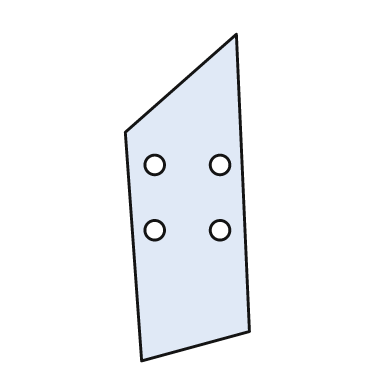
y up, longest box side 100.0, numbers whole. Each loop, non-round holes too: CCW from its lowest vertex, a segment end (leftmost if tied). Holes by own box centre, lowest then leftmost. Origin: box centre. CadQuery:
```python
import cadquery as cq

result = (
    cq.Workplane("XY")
    .moveTo(-14.0, -50.0)
    .lineTo(19.0, -41.0)
    .lineTo(15.0, 50.0)
    .lineTo(-19.0, 20.0)
    .close()
    .moveTo(-10.0, -10.0)
    .circle(3.0)
    .moveTo(10.0, -10.0)
    .circle(3.0)
    .moveTo(-10.0, 10.0)
    .circle(3.0)
    .moveTo(10.0, 10.0)
    .circle(3.0)
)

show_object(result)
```